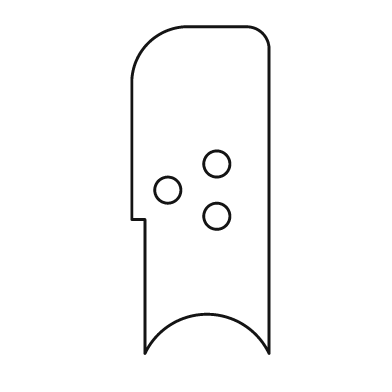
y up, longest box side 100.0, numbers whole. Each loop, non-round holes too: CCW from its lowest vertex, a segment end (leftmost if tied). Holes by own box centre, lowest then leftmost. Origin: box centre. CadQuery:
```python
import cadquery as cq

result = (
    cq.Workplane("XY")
    .moveTo(-17.0, -50.0)
    .threePointArc((2.0, -38.0), (21.0, -50.0))
    .lineTo(21.0, 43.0)
    .threePointArc((19.0, 48.0), (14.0, 50.0))
    .lineTo(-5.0, 50.0)
    .threePointArc((-16.0, 45.0), (-21.0, 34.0))
    .lineTo(-21.0, -9.0)
    .lineTo(-17.0, -9.0)
    .close()
    .moveTo(5.0, -8.0)
    .circle(4.0)
    .moveTo(-10.0, 0.0)
    .circle(4.0)
    .moveTo(5.0, 8.0)
    .circle(4.0)
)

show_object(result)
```